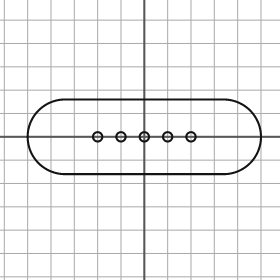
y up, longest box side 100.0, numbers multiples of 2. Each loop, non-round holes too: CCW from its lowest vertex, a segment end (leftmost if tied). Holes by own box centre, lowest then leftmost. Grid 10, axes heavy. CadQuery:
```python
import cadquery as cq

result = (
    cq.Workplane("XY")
    .moveTo(-34.0, -16.0)
    .lineTo(34.0, -16.0)
    .threePointArc((50.0, 0.0), (34.0, 16.0))
    .lineTo(-34.0, 16.0)
    .threePointArc((-50.0, 0.0), (-34.0, -16.0))
    .close()
    .moveTo(-20.0, 0.0)
    .circle(2.0)
    .moveTo(-10.0, 0.0)
    .circle(2.0)
    .moveTo(0.0, 0.0)
    .circle(2.0)
    .moveTo(10.0, 0.0)
    .circle(2.0)
    .moveTo(20.0, 0.0)
    .circle(2.0)
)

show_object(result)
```